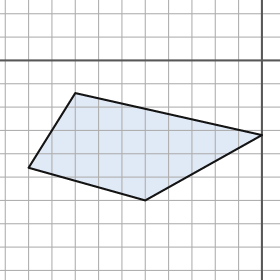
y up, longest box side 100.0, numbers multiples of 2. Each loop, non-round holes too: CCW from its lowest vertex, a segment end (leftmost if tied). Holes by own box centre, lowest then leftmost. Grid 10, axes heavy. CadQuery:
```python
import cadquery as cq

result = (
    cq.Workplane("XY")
    .moveTo(-50.0, -60.0)
    .lineTo(0.0, -32.0)
    .lineTo(-80.0, -14.0)
    .lineTo(-100.0, -46.0)
    .close()
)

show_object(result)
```